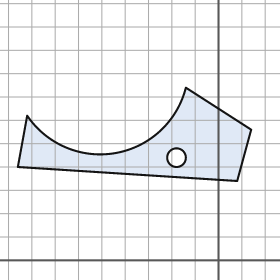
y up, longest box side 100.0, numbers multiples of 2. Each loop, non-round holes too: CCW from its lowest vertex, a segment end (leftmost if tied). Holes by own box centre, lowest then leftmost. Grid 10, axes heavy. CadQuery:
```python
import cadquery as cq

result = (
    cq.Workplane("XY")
    .moveTo(8.0, 34.0)
    .lineTo(14.0, 56.0)
    .lineTo(-14.0, 74.0)
    .threePointArc((-44.0, 46.0), (-82.0, 62.0))
    .lineTo(-86.0, 40.0)
    .close()
    .moveTo(-18.0, 44.0)
    .circle(4.0)
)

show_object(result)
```